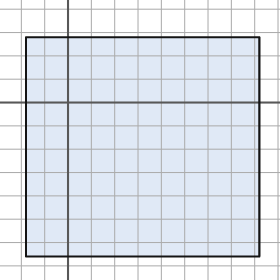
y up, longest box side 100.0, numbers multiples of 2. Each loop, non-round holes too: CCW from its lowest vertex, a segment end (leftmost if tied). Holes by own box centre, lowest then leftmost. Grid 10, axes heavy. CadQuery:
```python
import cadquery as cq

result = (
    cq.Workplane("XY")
    .moveTo(-18.0, -66.0)
    .lineTo(82.0, -66.0)
    .lineTo(82.0, 28.0)
    .lineTo(-18.0, 28.0)
    .close()
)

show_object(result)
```